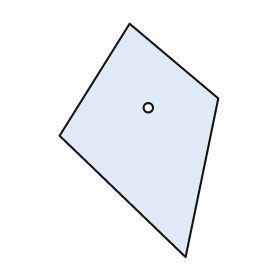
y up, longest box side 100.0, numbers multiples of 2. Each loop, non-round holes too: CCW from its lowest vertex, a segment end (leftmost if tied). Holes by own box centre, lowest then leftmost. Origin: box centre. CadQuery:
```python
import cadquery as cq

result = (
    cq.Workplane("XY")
    .moveTo(20.0, -50.0)
    .lineTo(34.0, 18.0)
    .lineTo(-4.0, 50.0)
    .lineTo(-34.0, 2.0)
    .close()
    .moveTo(4.0, 14.0)
    .circle(2.0)
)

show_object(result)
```